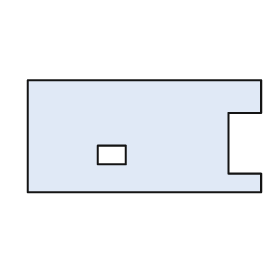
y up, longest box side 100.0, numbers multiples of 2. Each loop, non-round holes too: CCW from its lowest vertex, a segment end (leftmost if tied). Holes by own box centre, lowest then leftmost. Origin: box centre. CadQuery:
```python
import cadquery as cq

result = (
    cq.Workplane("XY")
    .moveTo(-50.0, -24.0)
    .lineTo(50.0, -24.0)
    .lineTo(50.0, -16.0)
    .lineTo(36.0, -16.0)
    .lineTo(36.0, 10.0)
    .lineTo(50.0, 10.0)
    .lineTo(50.0, 24.0)
    .lineTo(-50.0, 24.0)
    .close()
    .moveTo(-20.0, -12.0)
    .lineTo(-8.0, -12.0)
    .lineTo(-8.0, -4.0)
    .lineTo(-20.0, -4.0)
    .close()
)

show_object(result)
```